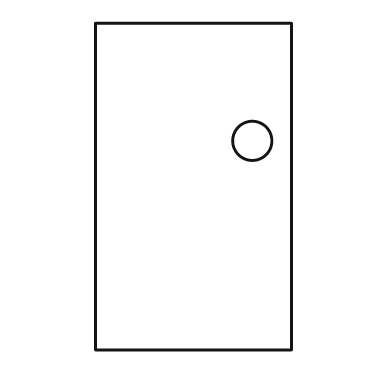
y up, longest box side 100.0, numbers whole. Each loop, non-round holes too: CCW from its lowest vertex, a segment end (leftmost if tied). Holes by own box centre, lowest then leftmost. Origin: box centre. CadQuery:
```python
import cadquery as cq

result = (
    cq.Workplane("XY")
    .moveTo(-30.0, -50.0)
    .lineTo(30.0, -50.0)
    .lineTo(30.0, 50.0)
    .lineTo(-30.0, 50.0)
    .close()
    .moveTo(18.0, 14.0)
    .circle(6.0)
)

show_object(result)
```